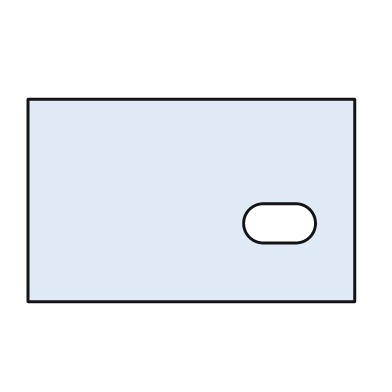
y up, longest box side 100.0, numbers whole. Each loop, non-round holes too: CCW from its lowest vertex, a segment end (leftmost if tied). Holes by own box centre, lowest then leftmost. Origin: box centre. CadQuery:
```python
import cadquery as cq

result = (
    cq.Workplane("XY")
    .moveTo(-50.0, -31.0)
    .lineTo(50.0, -31.0)
    .lineTo(50.0, 31.0)
    .lineTo(-50.0, 31.0)
    .close()
    .moveTo(22.0, -13.0)
    .lineTo(32.0, -13.0)
    .threePointArc((38.0, -7.0), (32.0, -1.0))
    .lineTo(22.0, -1.0)
    .threePointArc((16.0, -7.0), (22.0, -13.0))
    .close()
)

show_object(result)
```